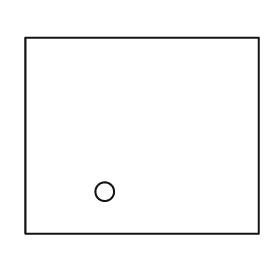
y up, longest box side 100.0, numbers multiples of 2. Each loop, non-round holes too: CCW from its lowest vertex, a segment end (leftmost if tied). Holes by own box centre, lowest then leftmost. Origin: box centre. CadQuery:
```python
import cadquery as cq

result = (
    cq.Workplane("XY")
    .moveTo(-50.0, -42.0)
    .lineTo(50.0, -42.0)
    .lineTo(50.0, 42.0)
    .lineTo(-50.0, 42.0)
    .close()
    .moveTo(-16.0, -24.0)
    .circle(4.0)
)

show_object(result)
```